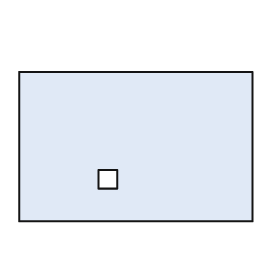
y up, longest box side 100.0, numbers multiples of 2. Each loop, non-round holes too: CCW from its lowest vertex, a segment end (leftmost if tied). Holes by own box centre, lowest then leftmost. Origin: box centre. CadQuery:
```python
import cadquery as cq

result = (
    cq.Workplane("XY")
    .moveTo(-50.0, -32.0)
    .lineTo(50.0, -32.0)
    .lineTo(50.0, 32.0)
    .lineTo(-50.0, 32.0)
    .close()
    .moveTo(-16.0, -18.0)
    .lineTo(-8.0, -18.0)
    .lineTo(-8.0, -10.0)
    .lineTo(-16.0, -10.0)
    .close()
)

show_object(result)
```